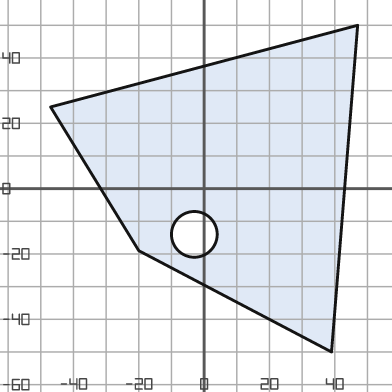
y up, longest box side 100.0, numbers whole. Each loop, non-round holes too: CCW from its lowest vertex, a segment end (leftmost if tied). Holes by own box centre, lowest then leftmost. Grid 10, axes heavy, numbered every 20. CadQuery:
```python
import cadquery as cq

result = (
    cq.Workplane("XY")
    .moveTo(39.0, -50.0)
    .lineTo(47.0, 50.0)
    .lineTo(-47.0, 25.0)
    .lineTo(-20.0, -19.0)
    .close()
    .moveTo(-3.0, -14.0)
    .circle(7.0)
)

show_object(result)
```